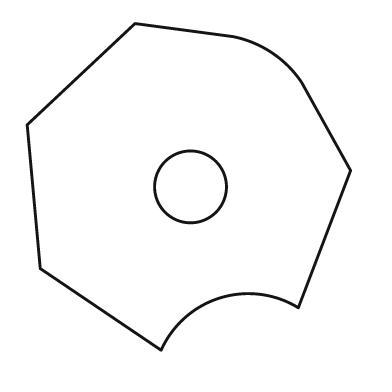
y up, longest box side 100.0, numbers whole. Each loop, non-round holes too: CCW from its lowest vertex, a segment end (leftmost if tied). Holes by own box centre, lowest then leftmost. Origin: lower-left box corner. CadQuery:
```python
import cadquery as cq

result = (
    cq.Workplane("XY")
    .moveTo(41.0, 0.0)
    .threePointArc((59.0, 16.0), (83.0, 13.0))
    .lineTo(99.0, 55.0)
    .lineTo(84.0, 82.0)
    .threePointArc((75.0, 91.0), (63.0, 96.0))
    .lineTo(33.0, 100.0)
    .lineTo(0.0, 69.0)
    .lineTo(4.0, 25.0)
    .close()
    .moveTo(50.0, 50.0)
    .circle(11.0)
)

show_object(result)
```